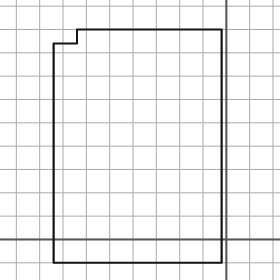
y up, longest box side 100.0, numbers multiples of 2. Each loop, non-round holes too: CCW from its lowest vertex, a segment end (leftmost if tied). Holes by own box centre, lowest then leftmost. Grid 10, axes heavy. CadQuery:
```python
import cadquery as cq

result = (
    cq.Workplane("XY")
    .moveTo(-74.0, -10.0)
    .lineTo(-2.0, -10.0)
    .lineTo(-2.0, 90.0)
    .lineTo(-64.0, 90.0)
    .lineTo(-64.0, 84.0)
    .lineTo(-74.0, 84.0)
    .close()
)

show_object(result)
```